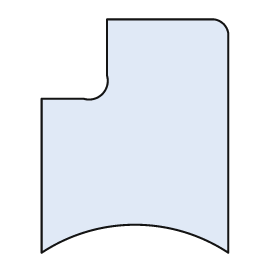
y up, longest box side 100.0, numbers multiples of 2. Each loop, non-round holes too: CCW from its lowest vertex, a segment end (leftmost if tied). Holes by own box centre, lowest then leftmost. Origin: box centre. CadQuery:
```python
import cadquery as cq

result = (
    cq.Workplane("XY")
    .moveTo(-40.0, -50.0)
    .threePointArc((0.0, -38.0), (40.0, -50.0))
    .lineTo(40.0, 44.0)
    .threePointArc((38.0, 48.0), (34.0, 50.0))
    .lineTo(-12.0, 50.0)
    .lineTo(-12.0, 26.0)
    .threePointArc((-14.0, 18.0), (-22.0, 16.0))
    .lineTo(-40.0, 16.0)
    .close()
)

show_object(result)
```